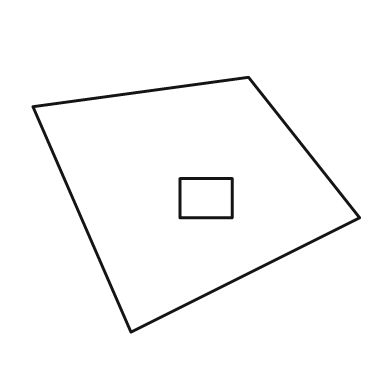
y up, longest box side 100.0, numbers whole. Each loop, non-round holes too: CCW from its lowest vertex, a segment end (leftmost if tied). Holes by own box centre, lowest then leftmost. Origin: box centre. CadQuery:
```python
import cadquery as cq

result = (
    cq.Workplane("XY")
    .moveTo(-20.0, -39.0)
    .lineTo(50.0, -4.0)
    .lineTo(16.0, 39.0)
    .lineTo(-50.0, 30.0)
    .close()
    .moveTo(-5.0, -4.0)
    .lineTo(11.0, -4.0)
    .lineTo(11.0, 8.0)
    .lineTo(-5.0, 8.0)
    .close()
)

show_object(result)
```